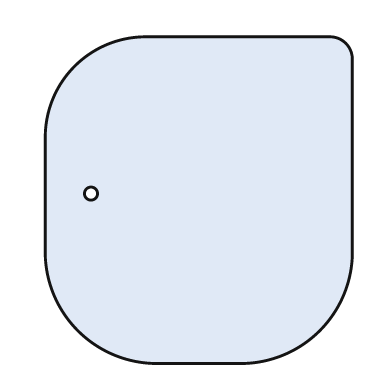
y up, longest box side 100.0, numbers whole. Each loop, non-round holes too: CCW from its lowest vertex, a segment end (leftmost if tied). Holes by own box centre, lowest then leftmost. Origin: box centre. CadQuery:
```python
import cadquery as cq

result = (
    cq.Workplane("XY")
    .moveTo(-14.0, -50.0)
    .lineTo(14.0, -50.0)
    .threePointArc((37.0, -40.0), (47.0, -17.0))
    .lineTo(47.0, 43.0)
    .threePointArc((45.0, 48.0), (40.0, 50.0))
    .lineTo(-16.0, 50.0)
    .threePointArc((-38.0, 41.0), (-47.0, 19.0))
    .lineTo(-47.0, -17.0)
    .threePointArc((-37.0, -40.0), (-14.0, -50.0))
    .close()
    .moveTo(-33.0, 2.0)
    .circle(2.0)
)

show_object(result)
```